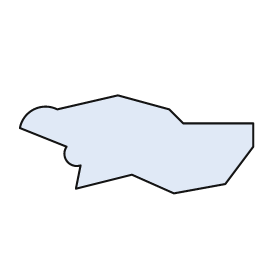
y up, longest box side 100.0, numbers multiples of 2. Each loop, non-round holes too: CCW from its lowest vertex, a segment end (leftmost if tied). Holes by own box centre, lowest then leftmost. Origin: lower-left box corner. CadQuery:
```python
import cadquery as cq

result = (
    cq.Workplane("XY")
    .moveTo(66.0, 0.0)
    .lineTo(88.0, 4.0)
    .lineTo(100.0, 20.0)
    .lineTo(100.0, 30.0)
    .lineTo(70.0, 30.0)
    .lineTo(64.0, 36.0)
    .lineTo(42.0, 42.0)
    .lineTo(16.0, 36.0)
    .threePointArc((6.0, 36.0), (0.0, 28.0))
    .lineTo(20.0, 20.0)
    .threePointArc((20.0, 14.0), (26.0, 12.0))
    .lineTo(24.0, 2.0)
    .lineTo(48.0, 8.0)
    .close()
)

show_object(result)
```